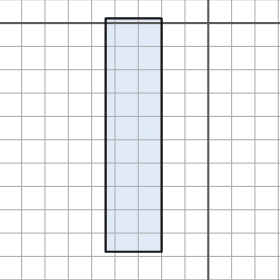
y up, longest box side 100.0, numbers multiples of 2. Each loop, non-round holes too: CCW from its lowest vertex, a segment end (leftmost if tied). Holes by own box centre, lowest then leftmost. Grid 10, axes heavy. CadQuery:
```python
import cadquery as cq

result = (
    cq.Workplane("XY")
    .moveTo(-44.0, -98.0)
    .lineTo(-20.0, -98.0)
    .lineTo(-20.0, 2.0)
    .lineTo(-44.0, 2.0)
    .close()
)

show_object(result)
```